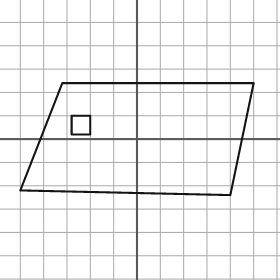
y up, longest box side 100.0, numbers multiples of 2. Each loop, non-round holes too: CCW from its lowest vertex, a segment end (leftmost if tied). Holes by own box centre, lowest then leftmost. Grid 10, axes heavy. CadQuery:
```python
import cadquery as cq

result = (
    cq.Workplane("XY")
    .moveTo(40.0, -24.0)
    .lineTo(50.0, 24.0)
    .lineTo(-32.0, 24.0)
    .lineTo(-50.0, -22.0)
    .close()
    .moveTo(-28.0, 2.0)
    .lineTo(-20.0, 2.0)
    .lineTo(-20.0, 10.0)
    .lineTo(-28.0, 10.0)
    .close()
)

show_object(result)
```